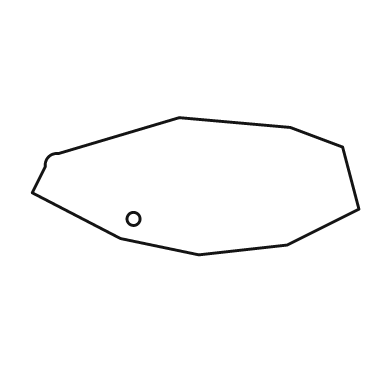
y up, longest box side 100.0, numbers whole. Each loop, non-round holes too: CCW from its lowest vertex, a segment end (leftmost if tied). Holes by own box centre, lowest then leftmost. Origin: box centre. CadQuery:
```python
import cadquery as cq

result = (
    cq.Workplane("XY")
    .moveTo(1.0, -21.0)
    .lineTo(28.0, -18.0)
    .lineTo(50.0, -7.0)
    .lineTo(45.0, 12.0)
    .lineTo(29.0, 18.0)
    .lineTo(-5.0, 21.0)
    .lineTo(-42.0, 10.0)
    .threePointArc((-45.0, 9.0), (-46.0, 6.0))
    .lineTo(-50.0, -2.0)
    .lineTo(-23.0, -16.0)
    .close()
    .moveTo(-19.0, -10.0)
    .circle(2.0)
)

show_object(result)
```